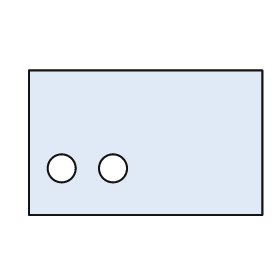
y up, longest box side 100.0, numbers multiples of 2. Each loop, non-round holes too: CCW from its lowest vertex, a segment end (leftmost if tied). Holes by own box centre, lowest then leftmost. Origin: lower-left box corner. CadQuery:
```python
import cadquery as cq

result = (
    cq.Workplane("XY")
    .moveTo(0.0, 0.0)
    .lineTo(100.0, 0.0)
    .lineTo(100.0, 62.0)
    .lineTo(0.0, 62.0)
    .close()
    .moveTo(14.0, 20.0)
    .circle(6.0)
    .moveTo(36.0, 20.0)
    .circle(6.0)
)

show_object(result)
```